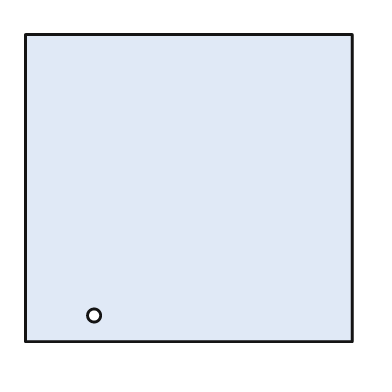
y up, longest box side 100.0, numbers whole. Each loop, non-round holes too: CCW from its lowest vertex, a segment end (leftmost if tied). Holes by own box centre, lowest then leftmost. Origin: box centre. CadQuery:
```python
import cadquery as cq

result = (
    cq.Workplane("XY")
    .moveTo(-50.0, -47.0)
    .lineTo(50.0, -47.0)
    .lineTo(50.0, 47.0)
    .lineTo(-50.0, 47.0)
    .close()
    .moveTo(-29.0, -39.0)
    .circle(2.0)
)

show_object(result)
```